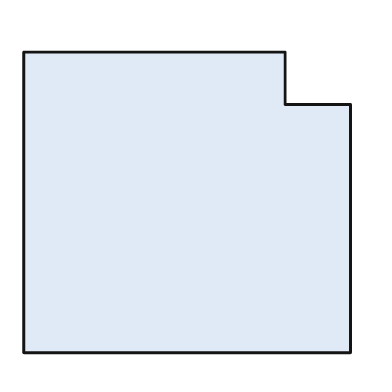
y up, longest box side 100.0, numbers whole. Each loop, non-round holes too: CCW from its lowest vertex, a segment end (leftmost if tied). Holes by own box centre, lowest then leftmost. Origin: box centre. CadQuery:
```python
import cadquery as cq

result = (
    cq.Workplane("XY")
    .moveTo(-50.0, -46.0)
    .lineTo(50.0, -46.0)
    .lineTo(50.0, 30.0)
    .lineTo(30.0, 30.0)
    .lineTo(30.0, 46.0)
    .lineTo(-50.0, 46.0)
    .close()
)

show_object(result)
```